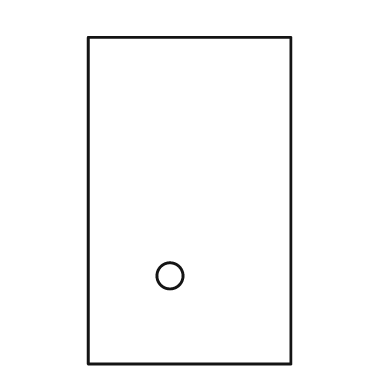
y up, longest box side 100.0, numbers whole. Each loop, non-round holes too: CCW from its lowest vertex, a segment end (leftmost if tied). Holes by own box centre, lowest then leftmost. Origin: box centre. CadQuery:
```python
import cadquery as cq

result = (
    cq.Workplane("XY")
    .moveTo(-31.0, -50.0)
    .lineTo(31.0, -50.0)
    .lineTo(31.0, 50.0)
    .lineTo(-31.0, 50.0)
    .close()
    .moveTo(-6.0, -23.0)
    .circle(4.0)
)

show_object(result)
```